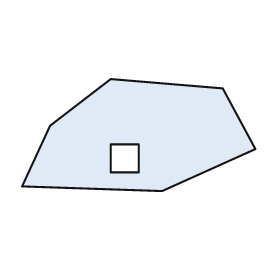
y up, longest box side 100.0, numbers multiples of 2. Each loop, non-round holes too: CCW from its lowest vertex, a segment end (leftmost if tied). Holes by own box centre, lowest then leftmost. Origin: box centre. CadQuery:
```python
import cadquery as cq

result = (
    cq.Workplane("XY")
    .moveTo(10.0, -24.0)
    .lineTo(50.0, -6.0)
    .lineTo(36.0, 20.0)
    .lineTo(-12.0, 24.0)
    .lineTo(-38.0, 4.0)
    .lineTo(-50.0, -22.0)
    .close()
    .moveTo(-12.0, -16.0)
    .lineTo(0.0, -16.0)
    .lineTo(0.0, -4.0)
    .lineTo(-12.0, -4.0)
    .close()
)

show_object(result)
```